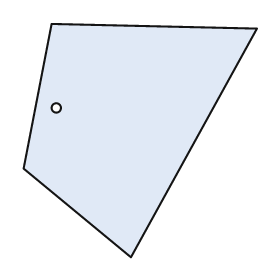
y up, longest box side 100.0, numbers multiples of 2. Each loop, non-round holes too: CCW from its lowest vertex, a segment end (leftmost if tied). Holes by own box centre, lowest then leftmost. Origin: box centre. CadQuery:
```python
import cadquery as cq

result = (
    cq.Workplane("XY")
    .moveTo(-4.0, -50.0)
    .lineTo(50.0, 48.0)
    .lineTo(-38.0, 50.0)
    .lineTo(-50.0, -12.0)
    .close()
    .moveTo(-36.0, 14.0)
    .circle(2.0)
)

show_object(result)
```